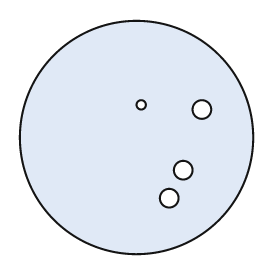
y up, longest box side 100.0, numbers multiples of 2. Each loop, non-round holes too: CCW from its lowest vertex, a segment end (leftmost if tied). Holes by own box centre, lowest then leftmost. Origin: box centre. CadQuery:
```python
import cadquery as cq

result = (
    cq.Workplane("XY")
    .moveTo(0.0, 0.0)
    .circle(50.0)
    .moveTo(14.0, -26.0)
    .circle(4.0)
    .moveTo(20.0, -14.0)
    .circle(4.0)
    .moveTo(28.0, 12.0)
    .circle(4.0)
    .moveTo(2.0, 14.0)
    .circle(2.0)
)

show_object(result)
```